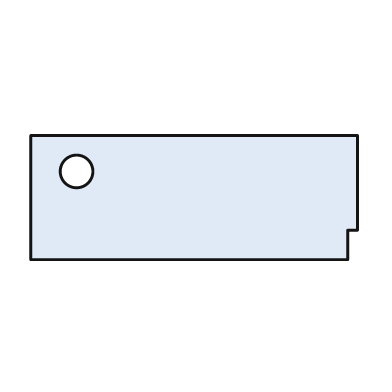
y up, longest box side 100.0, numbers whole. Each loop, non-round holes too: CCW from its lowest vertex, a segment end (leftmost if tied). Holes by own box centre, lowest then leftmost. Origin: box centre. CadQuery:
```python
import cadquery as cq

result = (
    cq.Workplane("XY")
    .moveTo(-50.0, -19.0)
    .lineTo(47.0, -19.0)
    .lineTo(47.0, -10.0)
    .lineTo(50.0, -10.0)
    .lineTo(50.0, 19.0)
    .lineTo(-50.0, 19.0)
    .close()
    .moveTo(-36.0, 8.0)
    .circle(5.0)
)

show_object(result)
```